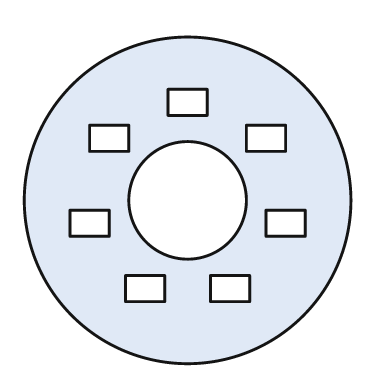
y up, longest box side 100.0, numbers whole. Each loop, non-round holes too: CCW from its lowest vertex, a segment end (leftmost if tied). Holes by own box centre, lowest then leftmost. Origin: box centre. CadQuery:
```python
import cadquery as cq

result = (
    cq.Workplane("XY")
    .moveTo(0.0, 0.0)
    .circle(50.0)
    .moveTo(-19.0, -31.0)
    .lineTo(-7.0, -31.0)
    .lineTo(-7.0, -23.0)
    .lineTo(-19.0, -23.0)
    .close()
    .moveTo(7.0, -31.0)
    .lineTo(19.0, -31.0)
    .lineTo(19.0, -23.0)
    .lineTo(7.0, -23.0)
    .close()
    .moveTo(-36.0, -11.0)
    .lineTo(-24.0, -11.0)
    .lineTo(-24.0, -3.0)
    .lineTo(-36.0, -3.0)
    .close()
    .moveTo(24.0, -11.0)
    .lineTo(36.0, -11.0)
    .lineTo(36.0, -3.0)
    .lineTo(24.0, -3.0)
    .close()
    .moveTo(0.0, 0.0)
    .circle(18.0)
    .moveTo(-30.0, 15.0)
    .lineTo(-18.0, 15.0)
    .lineTo(-18.0, 23.0)
    .lineTo(-30.0, 23.0)
    .close()
    .moveTo(18.0, 15.0)
    .lineTo(30.0, 15.0)
    .lineTo(30.0, 23.0)
    .lineTo(18.0, 23.0)
    .close()
    .moveTo(-6.0, 26.0)
    .lineTo(6.0, 26.0)
    .lineTo(6.0, 34.0)
    .lineTo(-6.0, 34.0)
    .close()
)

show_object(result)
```